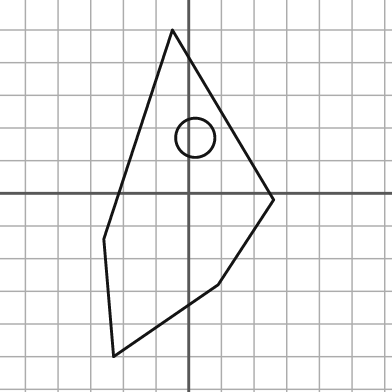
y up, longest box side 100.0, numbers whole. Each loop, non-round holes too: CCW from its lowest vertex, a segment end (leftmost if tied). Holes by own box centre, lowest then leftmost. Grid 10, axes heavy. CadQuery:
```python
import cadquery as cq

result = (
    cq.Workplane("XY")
    .moveTo(-23.0, -50.0)
    .lineTo(9.0, -28.0)
    .lineTo(26.0, -2.0)
    .lineTo(-5.0, 50.0)
    .lineTo(-26.0, -14.0)
    .close()
    .moveTo(2.0, 17.0)
    .circle(6.0)
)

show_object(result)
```